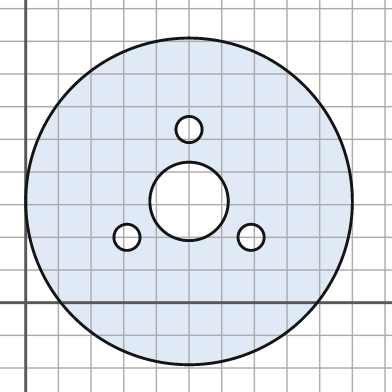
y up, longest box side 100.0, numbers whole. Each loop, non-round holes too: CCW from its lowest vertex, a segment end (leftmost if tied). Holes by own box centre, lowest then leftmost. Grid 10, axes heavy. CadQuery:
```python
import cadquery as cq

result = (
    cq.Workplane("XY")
    .moveTo(50.0, 31.0)
    .circle(50.0)
    .moveTo(31.0, 20.0)
    .circle(4.0)
    .moveTo(69.0, 20.0)
    .circle(4.0)
    .moveTo(50.0, 31.0)
    .circle(12.0)
    .moveTo(50.0, 53.0)
    .circle(4.0)
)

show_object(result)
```